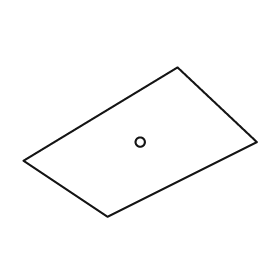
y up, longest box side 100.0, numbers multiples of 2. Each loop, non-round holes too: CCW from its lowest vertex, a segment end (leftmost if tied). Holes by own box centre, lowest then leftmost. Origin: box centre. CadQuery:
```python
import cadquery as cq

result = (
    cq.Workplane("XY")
    .moveTo(-14.0, -32.0)
    .lineTo(50.0, 0.0)
    .lineTo(16.0, 32.0)
    .lineTo(-50.0, -8.0)
    .close()
    .moveTo(0.0, 0.0)
    .circle(2.0)
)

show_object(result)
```